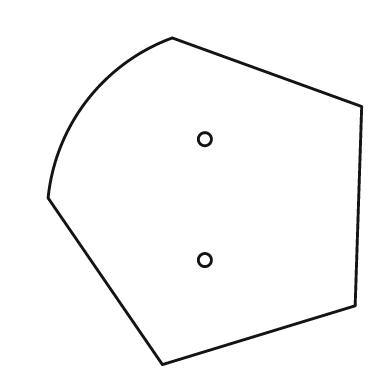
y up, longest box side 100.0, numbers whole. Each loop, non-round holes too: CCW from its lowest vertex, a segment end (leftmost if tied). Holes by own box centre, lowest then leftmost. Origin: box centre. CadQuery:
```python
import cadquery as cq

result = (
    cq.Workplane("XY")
    .moveTo(-13.0, -50.0)
    .lineTo(46.0, -32.0)
    .lineTo(48.0, 29.0)
    .lineTo(-10.0, 50.0)
    .threePointArc((-36.0, 31.0), (-48.0, 1.0))
    .close()
    .moveTo(0.0, -18.0)
    .circle(2.0)
    .moveTo(0.0, 19.0)
    .circle(2.0)
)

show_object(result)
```